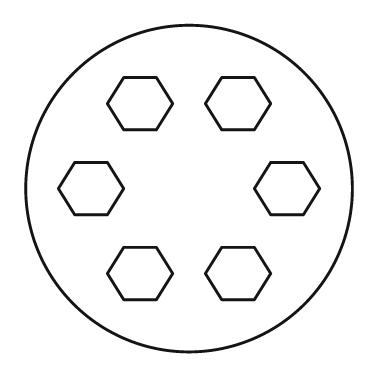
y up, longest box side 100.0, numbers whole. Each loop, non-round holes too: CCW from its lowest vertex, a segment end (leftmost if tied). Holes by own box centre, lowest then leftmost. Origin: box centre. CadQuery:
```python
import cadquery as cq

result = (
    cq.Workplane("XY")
    .moveTo(0.0, 0.0)
    .circle(50.0)
    .moveTo(-20.0, -34.0)
    .lineTo(-10.0, -34.0)
    .lineTo(-5.0, -26.0)
    .lineTo(-10.0, -18.0)
    .lineTo(-20.0, -18.0)
    .lineTo(-25.0, -26.0)
    .close()
    .moveTo(10.0, -34.0)
    .lineTo(20.0, -34.0)
    .lineTo(25.0, -26.0)
    .lineTo(20.0, -18.0)
    .lineTo(10.0, -18.0)
    .lineTo(5.0, -26.0)
    .close()
    .moveTo(-35.0, -8.0)
    .lineTo(-25.0, -8.0)
    .lineTo(-20.0, 0.0)
    .lineTo(-25.0, 8.0)
    .lineTo(-35.0, 8.0)
    .lineTo(-40.0, 0.0)
    .close()
    .moveTo(25.0, -8.0)
    .lineTo(35.0, -8.0)
    .lineTo(40.0, 0.0)
    .lineTo(35.0, 8.0)
    .lineTo(25.0, 8.0)
    .lineTo(20.0, 0.0)
    .close()
    .moveTo(-20.0, 18.0)
    .lineTo(-10.0, 18.0)
    .lineTo(-5.0, 26.0)
    .lineTo(-10.0, 34.0)
    .lineTo(-20.0, 34.0)
    .lineTo(-25.0, 26.0)
    .close()
    .moveTo(10.0, 18.0)
    .lineTo(20.0, 18.0)
    .lineTo(25.0, 26.0)
    .lineTo(20.0, 34.0)
    .lineTo(10.0, 34.0)
    .lineTo(5.0, 26.0)
    .close()
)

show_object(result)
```